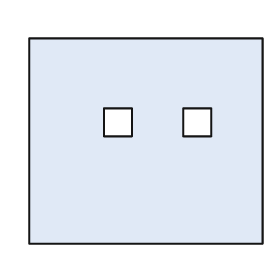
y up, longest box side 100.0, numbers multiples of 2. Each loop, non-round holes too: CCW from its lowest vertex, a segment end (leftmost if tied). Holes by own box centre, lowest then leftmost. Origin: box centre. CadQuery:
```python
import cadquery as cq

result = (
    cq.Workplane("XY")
    .moveTo(-50.0, -44.0)
    .lineTo(50.0, -44.0)
    .lineTo(50.0, 44.0)
    .lineTo(-50.0, 44.0)
    .close()
    .moveTo(-18.0, 2.0)
    .lineTo(-6.0, 2.0)
    .lineTo(-6.0, 14.0)
    .lineTo(-18.0, 14.0)
    .close()
    .moveTo(16.0, 2.0)
    .lineTo(28.0, 2.0)
    .lineTo(28.0, 14.0)
    .lineTo(16.0, 14.0)
    .close()
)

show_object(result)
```